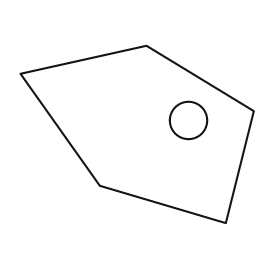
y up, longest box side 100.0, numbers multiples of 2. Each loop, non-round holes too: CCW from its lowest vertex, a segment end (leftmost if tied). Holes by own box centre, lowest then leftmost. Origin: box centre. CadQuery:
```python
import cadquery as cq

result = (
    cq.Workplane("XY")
    .moveTo(38.0, -38.0)
    .lineTo(50.0, 10.0)
    .lineTo(4.0, 38.0)
    .lineTo(-50.0, 26.0)
    .lineTo(-16.0, -22.0)
    .close()
    .moveTo(22.0, 6.0)
    .circle(8.0)
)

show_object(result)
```